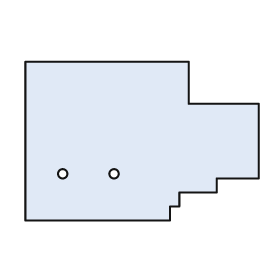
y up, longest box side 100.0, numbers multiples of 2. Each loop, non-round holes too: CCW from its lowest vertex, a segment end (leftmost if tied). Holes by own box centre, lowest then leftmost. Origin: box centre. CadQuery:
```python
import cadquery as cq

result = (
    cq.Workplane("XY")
    .moveTo(-50.0, -34.0)
    .lineTo(12.0, -34.0)
    .lineTo(12.0, -28.0)
    .lineTo(16.0, -28.0)
    .lineTo(16.0, -22.0)
    .lineTo(32.0, -22.0)
    .lineTo(32.0, -16.0)
    .lineTo(50.0, -16.0)
    .lineTo(50.0, 16.0)
    .lineTo(20.0, 16.0)
    .lineTo(20.0, 34.0)
    .lineTo(-50.0, 34.0)
    .close()
    .moveTo(-34.0, -14.0)
    .circle(2.0)
    .moveTo(-12.0, -14.0)
    .circle(2.0)
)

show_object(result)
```